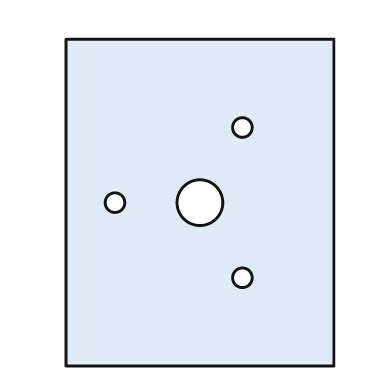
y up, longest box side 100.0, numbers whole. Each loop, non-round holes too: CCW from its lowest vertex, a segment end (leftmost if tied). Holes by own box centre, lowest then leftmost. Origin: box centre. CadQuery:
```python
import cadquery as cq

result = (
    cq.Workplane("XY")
    .moveTo(-41.0, -50.0)
    .lineTo(41.0, -50.0)
    .lineTo(41.0, 50.0)
    .lineTo(-41.0, 50.0)
    .close()
    .moveTo(13.0, -23.0)
    .circle(3.0)
    .moveTo(-26.0, 0.0)
    .circle(3.0)
    .moveTo(0.0, 0.0)
    .circle(7.0)
    .moveTo(13.0, 23.0)
    .circle(3.0)
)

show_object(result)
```